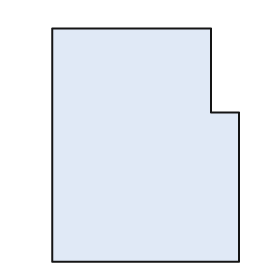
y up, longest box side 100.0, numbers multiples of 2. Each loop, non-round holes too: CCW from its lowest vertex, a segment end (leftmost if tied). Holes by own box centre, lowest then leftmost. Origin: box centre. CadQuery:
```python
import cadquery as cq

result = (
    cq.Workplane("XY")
    .moveTo(-40.0, -50.0)
    .lineTo(40.0, -50.0)
    .lineTo(40.0, 14.0)
    .lineTo(28.0, 14.0)
    .lineTo(28.0, 50.0)
    .lineTo(-40.0, 50.0)
    .close()
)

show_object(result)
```